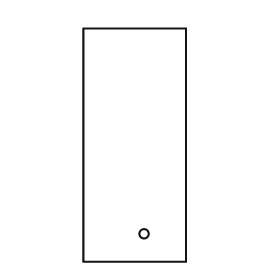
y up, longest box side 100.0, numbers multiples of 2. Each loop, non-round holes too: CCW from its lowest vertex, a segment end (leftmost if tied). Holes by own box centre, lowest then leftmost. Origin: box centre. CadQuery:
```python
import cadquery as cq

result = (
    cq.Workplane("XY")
    .moveTo(-22.0, -50.0)
    .lineTo(22.0, -50.0)
    .lineTo(22.0, 50.0)
    .lineTo(-22.0, 50.0)
    .close()
    .moveTo(4.0, -38.0)
    .circle(2.0)
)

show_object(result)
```